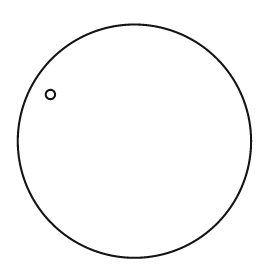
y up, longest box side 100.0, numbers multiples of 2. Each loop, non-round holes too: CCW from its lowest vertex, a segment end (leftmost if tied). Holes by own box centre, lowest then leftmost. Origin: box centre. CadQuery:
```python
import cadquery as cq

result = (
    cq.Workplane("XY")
    .moveTo(0.0, 0.0)
    .circle(50.0)
    .moveTo(-36.0, 20.0)
    .circle(2.0)
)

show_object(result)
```